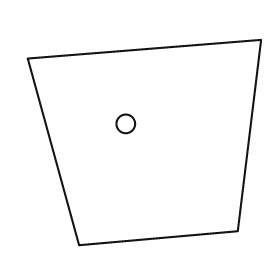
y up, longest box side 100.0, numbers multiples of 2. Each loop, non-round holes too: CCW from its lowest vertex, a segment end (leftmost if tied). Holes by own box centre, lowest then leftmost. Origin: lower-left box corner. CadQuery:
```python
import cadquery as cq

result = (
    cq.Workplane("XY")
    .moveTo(22.0, 0.0)
    .lineTo(90.0, 6.0)
    .lineTo(100.0, 88.0)
    .lineTo(0.0, 80.0)
    .close()
    .moveTo(42.0, 52.0)
    .circle(4.0)
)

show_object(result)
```